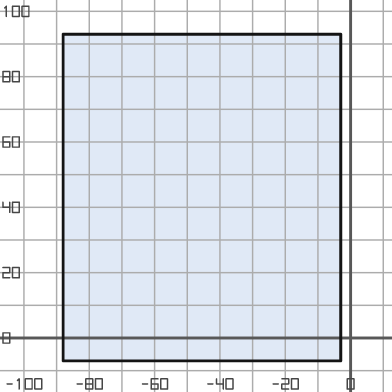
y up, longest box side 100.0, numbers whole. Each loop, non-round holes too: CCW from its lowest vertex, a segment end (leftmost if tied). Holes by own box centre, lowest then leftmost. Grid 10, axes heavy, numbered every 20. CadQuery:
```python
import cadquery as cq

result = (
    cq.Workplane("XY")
    .moveTo(-88.0, -7.0)
    .lineTo(-3.0, -7.0)
    .lineTo(-3.0, 93.0)
    .lineTo(-88.0, 93.0)
    .close()
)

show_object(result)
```